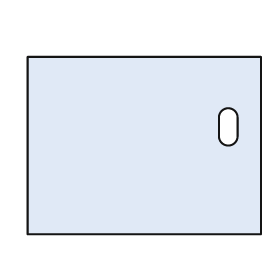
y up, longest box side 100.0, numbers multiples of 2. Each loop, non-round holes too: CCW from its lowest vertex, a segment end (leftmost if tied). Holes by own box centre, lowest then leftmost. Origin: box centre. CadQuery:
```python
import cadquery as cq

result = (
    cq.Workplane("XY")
    .moveTo(-50.0, -38.0)
    .lineTo(50.0, -38.0)
    .lineTo(50.0, 38.0)
    .lineTo(-50.0, 38.0)
    .close()
    .moveTo(32.0, 4.0)
    .threePointArc((36.0, 0.0), (40.0, 4.0))
    .lineTo(40.0, 12.0)
    .threePointArc((36.0, 16.0), (32.0, 12.0))
    .close()
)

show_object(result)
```